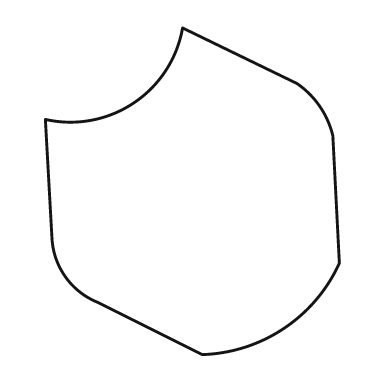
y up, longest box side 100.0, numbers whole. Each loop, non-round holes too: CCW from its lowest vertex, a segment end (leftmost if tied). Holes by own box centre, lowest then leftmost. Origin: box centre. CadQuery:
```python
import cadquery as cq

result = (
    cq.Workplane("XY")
    .moveTo(3.0, -50.0)
    .threePointArc((28.0, -42.0), (45.0, -22.0))
    .lineTo(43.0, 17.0)
    .threePointArc((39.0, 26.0), (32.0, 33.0))
    .lineTo(-3.0, 50.0)
    .threePointArc((-18.0, 27.0), (-45.0, 22.0))
    .lineTo(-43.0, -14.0)
    .threePointArc((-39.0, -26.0), (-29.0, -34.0))
    .close()
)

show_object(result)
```